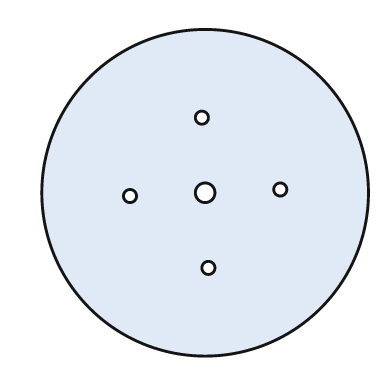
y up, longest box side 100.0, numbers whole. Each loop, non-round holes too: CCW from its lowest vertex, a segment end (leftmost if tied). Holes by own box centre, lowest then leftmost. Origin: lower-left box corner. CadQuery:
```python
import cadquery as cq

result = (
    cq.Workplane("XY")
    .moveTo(50.0, 50.0)
    .circle(50.0)
    .moveTo(51.0, 27.0)
    .circle(2.0)
    .moveTo(27.0, 49.0)
    .circle(2.0)
    .moveTo(50.0, 50.0)
    .circle(3.0)
    .moveTo(73.0, 51.0)
    .circle(2.0)
    .moveTo(49.0, 73.0)
    .circle(2.0)
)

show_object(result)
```